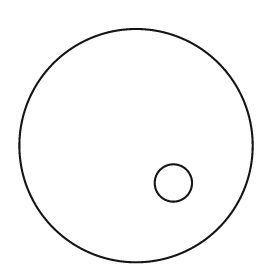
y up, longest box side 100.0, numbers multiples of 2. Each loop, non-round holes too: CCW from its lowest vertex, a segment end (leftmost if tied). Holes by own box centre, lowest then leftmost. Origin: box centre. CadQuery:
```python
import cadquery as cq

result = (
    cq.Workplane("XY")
    .moveTo(0.0, 0.0)
    .circle(50.0)
    .moveTo(16.0, -16.0)
    .circle(8.0)
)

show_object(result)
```